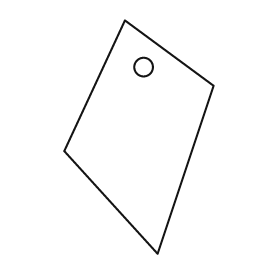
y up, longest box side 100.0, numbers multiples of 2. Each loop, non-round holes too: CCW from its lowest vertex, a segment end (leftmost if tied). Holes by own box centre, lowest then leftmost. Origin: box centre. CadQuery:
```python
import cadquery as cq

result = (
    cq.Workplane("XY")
    .moveTo(8.0, -50.0)
    .lineTo(32.0, 22.0)
    .lineTo(-6.0, 50.0)
    .lineTo(-32.0, -6.0)
    .close()
    .moveTo(2.0, 30.0)
    .circle(4.0)
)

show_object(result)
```